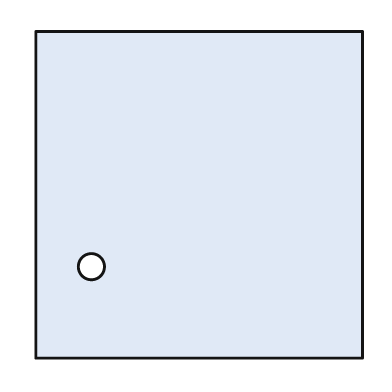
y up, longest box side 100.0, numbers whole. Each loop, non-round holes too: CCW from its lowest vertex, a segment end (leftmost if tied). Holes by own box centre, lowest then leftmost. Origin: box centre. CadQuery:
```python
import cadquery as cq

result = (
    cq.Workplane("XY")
    .moveTo(-50.0, -50.0)
    .lineTo(50.0, -50.0)
    .lineTo(50.0, 50.0)
    .lineTo(-50.0, 50.0)
    .close()
    .moveTo(-33.0, -22.0)
    .circle(4.0)
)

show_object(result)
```